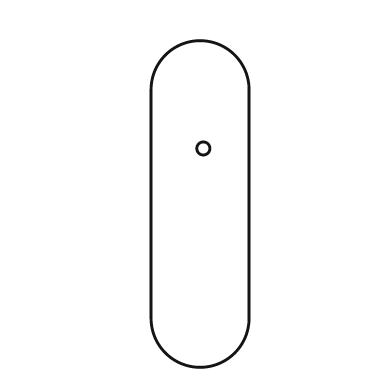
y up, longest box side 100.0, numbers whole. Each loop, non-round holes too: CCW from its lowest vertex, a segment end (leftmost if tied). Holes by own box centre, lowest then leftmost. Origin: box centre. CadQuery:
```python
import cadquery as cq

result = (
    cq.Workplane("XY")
    .moveTo(-15.0, -35.0)
    .threePointArc((0.0, -50.0), (15.0, -35.0))
    .lineTo(15.0, 35.0)
    .threePointArc((0.0, 50.0), (-15.0, 35.0))
    .close()
    .moveTo(1.0, 17.0)
    .circle(2.0)
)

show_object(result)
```